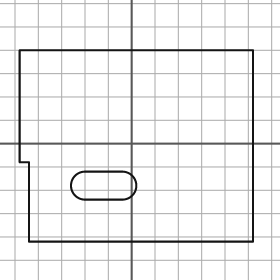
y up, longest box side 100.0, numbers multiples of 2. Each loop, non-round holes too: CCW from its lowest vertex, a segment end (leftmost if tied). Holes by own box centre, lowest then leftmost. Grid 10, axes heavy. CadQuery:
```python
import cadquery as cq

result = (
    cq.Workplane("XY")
    .moveTo(-44.0, -42.0)
    .lineTo(52.0, -42.0)
    .lineTo(52.0, 40.0)
    .lineTo(-48.0, 40.0)
    .lineTo(-48.0, -8.0)
    .lineTo(-44.0, -8.0)
    .close()
    .moveTo(-20.0, -24.0)
    .lineTo(-4.0, -24.0)
    .threePointArc((2.0, -18.0), (-4.0, -12.0))
    .lineTo(-20.0, -12.0)
    .threePointArc((-26.0, -18.0), (-20.0, -24.0))
    .close()
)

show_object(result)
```